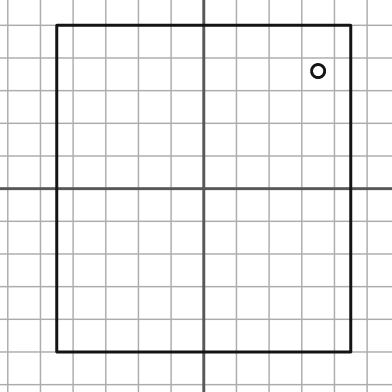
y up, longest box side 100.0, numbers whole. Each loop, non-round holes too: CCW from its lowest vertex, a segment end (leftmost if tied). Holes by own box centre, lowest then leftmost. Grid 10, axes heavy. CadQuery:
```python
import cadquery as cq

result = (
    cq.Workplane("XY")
    .moveTo(-45.0, -50.0)
    .lineTo(45.0, -50.0)
    .lineTo(45.0, 50.0)
    .lineTo(-45.0, 50.0)
    .close()
    .moveTo(35.0, 36.0)
    .circle(2.0)
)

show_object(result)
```